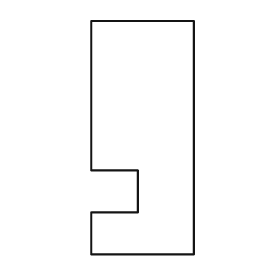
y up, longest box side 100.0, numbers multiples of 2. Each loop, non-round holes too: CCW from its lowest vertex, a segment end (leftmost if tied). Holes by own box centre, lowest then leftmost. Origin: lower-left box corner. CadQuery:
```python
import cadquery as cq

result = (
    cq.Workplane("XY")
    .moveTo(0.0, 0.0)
    .lineTo(44.0, 0.0)
    .lineTo(44.0, 100.0)
    .lineTo(0.0, 100.0)
    .lineTo(0.0, 36.0)
    .lineTo(20.0, 36.0)
    .lineTo(20.0, 18.0)
    .lineTo(0.0, 18.0)
    .close()
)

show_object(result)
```